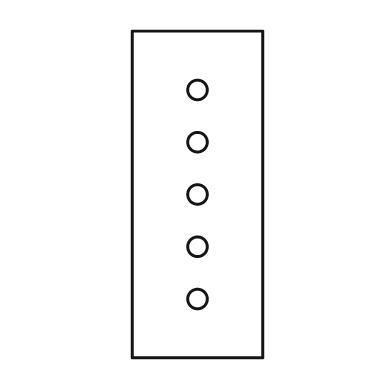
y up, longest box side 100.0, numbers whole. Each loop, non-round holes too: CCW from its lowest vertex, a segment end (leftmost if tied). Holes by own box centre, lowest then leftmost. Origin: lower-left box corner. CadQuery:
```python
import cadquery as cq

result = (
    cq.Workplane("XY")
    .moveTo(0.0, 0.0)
    .lineTo(40.0, 0.0)
    .lineTo(40.0, 100.0)
    .lineTo(0.0, 100.0)
    .close()
    .moveTo(20.0, 18.0)
    .circle(3.0)
    .moveTo(20.0, 34.0)
    .circle(3.0)
    .moveTo(20.0, 50.0)
    .circle(3.0)
    .moveTo(20.0, 66.0)
    .circle(3.0)
    .moveTo(20.0, 82.0)
    .circle(3.0)
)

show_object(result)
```